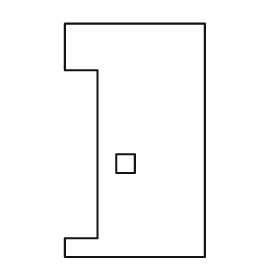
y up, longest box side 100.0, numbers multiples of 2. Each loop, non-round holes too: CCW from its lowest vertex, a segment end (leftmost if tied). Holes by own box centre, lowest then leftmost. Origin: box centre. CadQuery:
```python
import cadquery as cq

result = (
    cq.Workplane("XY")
    .moveTo(-30.0, -50.0)
    .lineTo(30.0, -50.0)
    .lineTo(30.0, 50.0)
    .lineTo(-30.0, 50.0)
    .lineTo(-30.0, 30.0)
    .lineTo(-16.0, 30.0)
    .lineTo(-16.0, -42.0)
    .lineTo(-30.0, -42.0)
    .close()
    .moveTo(-8.0, -14.0)
    .lineTo(0.0, -14.0)
    .lineTo(0.0, -6.0)
    .lineTo(-8.0, -6.0)
    .close()
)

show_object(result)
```